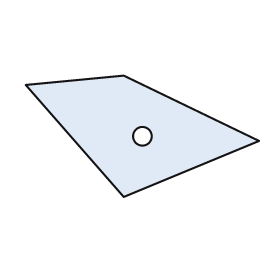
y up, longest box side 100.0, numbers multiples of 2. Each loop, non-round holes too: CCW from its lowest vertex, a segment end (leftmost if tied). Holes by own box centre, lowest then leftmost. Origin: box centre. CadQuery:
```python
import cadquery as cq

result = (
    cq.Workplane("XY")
    .moveTo(-8.0, -26.0)
    .lineTo(50.0, -2.0)
    .lineTo(-8.0, 26.0)
    .lineTo(-50.0, 22.0)
    .close()
    .moveTo(0.0, 0.0)
    .circle(4.0)
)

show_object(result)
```